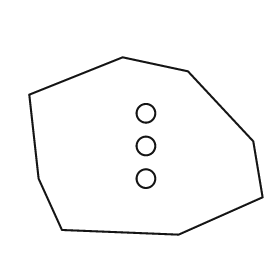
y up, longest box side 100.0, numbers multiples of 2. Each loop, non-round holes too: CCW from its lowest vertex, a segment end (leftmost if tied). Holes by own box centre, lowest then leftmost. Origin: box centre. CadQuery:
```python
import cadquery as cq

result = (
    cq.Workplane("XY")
    .moveTo(14.0, -38.0)
    .lineTo(50.0, -22.0)
    .lineTo(46.0, 2.0)
    .lineTo(18.0, 32.0)
    .lineTo(-10.0, 38.0)
    .lineTo(-50.0, 22.0)
    .lineTo(-46.0, -14.0)
    .lineTo(-36.0, -36.0)
    .close()
    .moveTo(0.0, -14.0)
    .circle(4.0)
    .moveTo(0.0, 0.0)
    .circle(4.0)
    .moveTo(0.0, 14.0)
    .circle(4.0)
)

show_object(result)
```